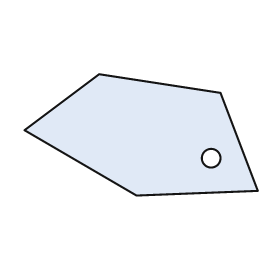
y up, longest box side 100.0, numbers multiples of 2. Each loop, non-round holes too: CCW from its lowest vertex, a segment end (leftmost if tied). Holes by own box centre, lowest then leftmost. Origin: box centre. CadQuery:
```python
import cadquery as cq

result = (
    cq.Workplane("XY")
    .moveTo(-2.0, -26.0)
    .lineTo(50.0, -24.0)
    .lineTo(34.0, 18.0)
    .lineTo(-18.0, 26.0)
    .lineTo(-50.0, 2.0)
    .close()
    .moveTo(30.0, -10.0)
    .circle(4.0)
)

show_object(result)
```